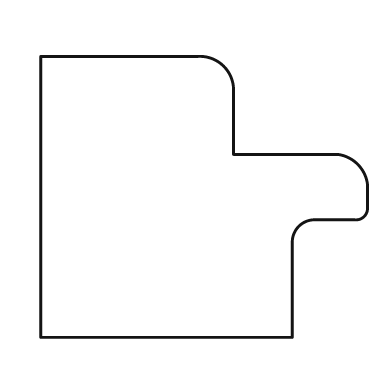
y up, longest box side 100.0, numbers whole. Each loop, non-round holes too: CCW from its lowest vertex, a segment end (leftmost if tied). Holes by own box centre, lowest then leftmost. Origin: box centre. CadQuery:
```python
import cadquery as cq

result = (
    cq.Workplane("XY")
    .moveTo(-50.0, -43.0)
    .lineTo(27.0, -43.0)
    .lineTo(27.0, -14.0)
    .threePointArc((29.0, -9.0), (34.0, -7.0))
    .lineTo(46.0, -7.0)
    .threePointArc((49.0, -6.0), (50.0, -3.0))
    .lineTo(50.0, 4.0)
    .threePointArc((47.0, 10.0), (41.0, 13.0))
    .lineTo(9.0, 13.0)
    .lineTo(9.0, 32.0)
    .threePointArc((6.0, 40.0), (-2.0, 43.0))
    .lineTo(-50.0, 43.0)
    .close()
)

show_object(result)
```